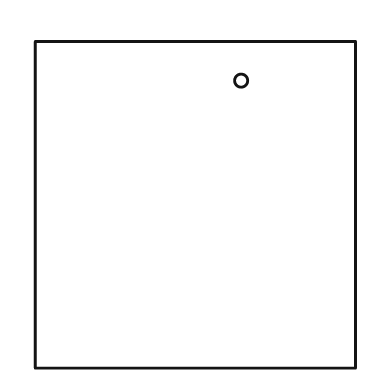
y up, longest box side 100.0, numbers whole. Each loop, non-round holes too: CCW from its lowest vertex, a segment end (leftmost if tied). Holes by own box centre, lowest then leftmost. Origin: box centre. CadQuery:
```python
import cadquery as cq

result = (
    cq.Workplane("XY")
    .moveTo(-49.0, -50.0)
    .lineTo(49.0, -50.0)
    .lineTo(49.0, 50.0)
    .lineTo(-49.0, 50.0)
    .close()
    .moveTo(14.0, 38.0)
    .circle(2.0)
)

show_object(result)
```